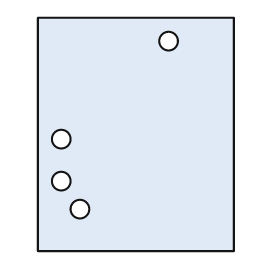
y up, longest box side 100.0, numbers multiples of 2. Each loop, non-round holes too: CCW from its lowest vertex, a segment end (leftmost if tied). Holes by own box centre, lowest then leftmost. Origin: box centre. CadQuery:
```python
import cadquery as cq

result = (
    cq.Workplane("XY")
    .moveTo(-42.0, -50.0)
    .lineTo(42.0, -50.0)
    .lineTo(42.0, 50.0)
    .lineTo(-42.0, 50.0)
    .close()
    .moveTo(-24.0, -32.0)
    .circle(4.0)
    .moveTo(-32.0, -20.0)
    .circle(4.0)
    .moveTo(-32.0, -2.0)
    .circle(4.0)
    .moveTo(14.0, 40.0)
    .circle(4.0)
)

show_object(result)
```